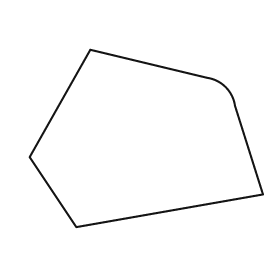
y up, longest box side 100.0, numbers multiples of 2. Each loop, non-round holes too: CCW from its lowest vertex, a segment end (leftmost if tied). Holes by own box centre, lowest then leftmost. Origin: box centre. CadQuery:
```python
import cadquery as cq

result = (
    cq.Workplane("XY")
    .moveTo(-30.0, -38.0)
    .lineTo(50.0, -24.0)
    .lineTo(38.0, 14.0)
    .threePointArc((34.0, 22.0), (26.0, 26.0))
    .lineTo(-24.0, 38.0)
    .lineTo(-50.0, -8.0)
    .close()
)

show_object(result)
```